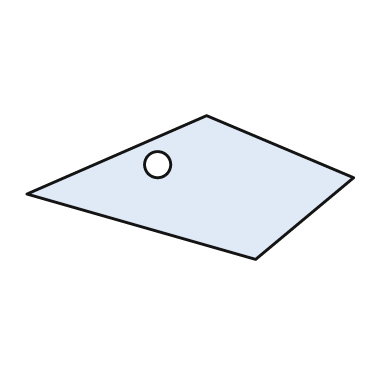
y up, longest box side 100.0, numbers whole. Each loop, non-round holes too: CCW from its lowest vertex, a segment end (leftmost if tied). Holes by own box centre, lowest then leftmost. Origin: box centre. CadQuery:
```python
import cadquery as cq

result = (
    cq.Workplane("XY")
    .moveTo(20.0, -22.0)
    .lineTo(50.0, 3.0)
    .lineTo(5.0, 22.0)
    .lineTo(-50.0, -2.0)
    .close()
    .moveTo(-10.0, 7.0)
    .circle(4.0)
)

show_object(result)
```